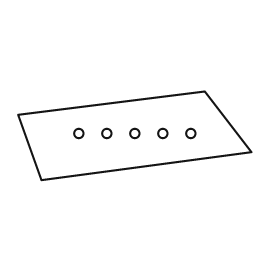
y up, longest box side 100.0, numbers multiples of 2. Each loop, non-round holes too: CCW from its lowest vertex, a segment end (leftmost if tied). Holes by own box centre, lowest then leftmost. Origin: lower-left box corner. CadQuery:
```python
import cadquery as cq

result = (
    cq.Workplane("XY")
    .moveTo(10.0, 0.0)
    .lineTo(100.0, 12.0)
    .lineTo(80.0, 38.0)
    .lineTo(0.0, 28.0)
    .close()
    .moveTo(26.0, 20.0)
    .circle(2.0)
    .moveTo(38.0, 20.0)
    .circle(2.0)
    .moveTo(50.0, 20.0)
    .circle(2.0)
    .moveTo(62.0, 20.0)
    .circle(2.0)
    .moveTo(74.0, 20.0)
    .circle(2.0)
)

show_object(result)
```